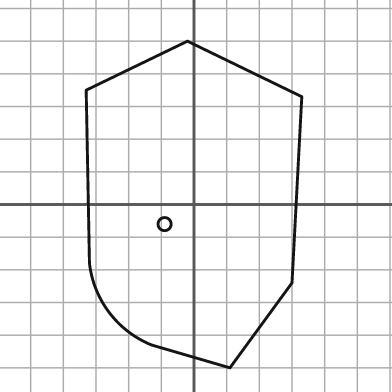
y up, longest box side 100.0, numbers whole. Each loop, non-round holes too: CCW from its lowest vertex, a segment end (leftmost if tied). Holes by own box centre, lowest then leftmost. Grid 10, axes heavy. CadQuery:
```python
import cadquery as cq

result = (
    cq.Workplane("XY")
    .moveTo(11.0, -50.0)
    .lineTo(30.0, -24.0)
    .lineTo(33.0, 33.0)
    .lineTo(-2.0, 50.0)
    .lineTo(-33.0, 35.0)
    .lineTo(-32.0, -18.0)
    .threePointArc((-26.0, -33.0), (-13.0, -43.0))
    .close()
    .moveTo(-9.0, -6.0)
    .circle(2.0)
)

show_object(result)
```